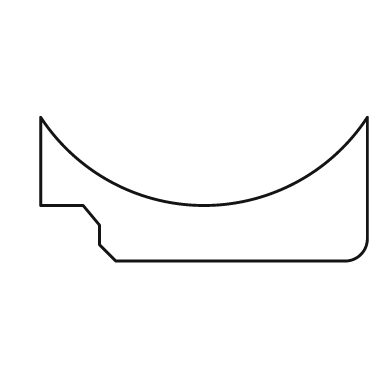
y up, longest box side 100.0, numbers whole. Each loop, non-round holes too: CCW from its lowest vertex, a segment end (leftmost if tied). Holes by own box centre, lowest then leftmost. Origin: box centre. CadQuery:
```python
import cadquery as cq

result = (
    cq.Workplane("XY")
    .moveTo(-27.0, -22.0)
    .lineTo(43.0, -22.0)
    .threePointArc((48.0, -20.0), (50.0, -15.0))
    .lineTo(50.0, 22.0)
    .threePointArc((0.0, -5.0), (-50.0, 22.0))
    .lineTo(-50.0, -5.0)
    .lineTo(-37.0, -5.0)
    .lineTo(-32.0, -11.0)
    .lineTo(-32.0, -17.0)
    .close()
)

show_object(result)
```